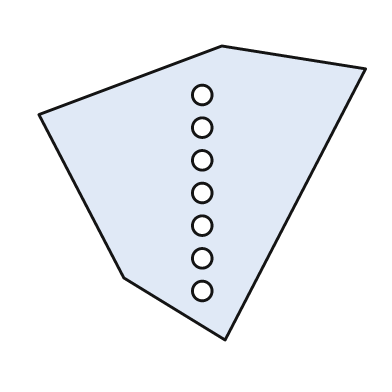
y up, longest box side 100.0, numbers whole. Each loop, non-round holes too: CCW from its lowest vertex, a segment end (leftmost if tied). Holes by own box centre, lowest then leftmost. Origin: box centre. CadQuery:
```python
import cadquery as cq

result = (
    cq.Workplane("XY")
    .moveTo(7.0, -45.0)
    .lineTo(50.0, 38.0)
    .lineTo(6.0, 45.0)
    .lineTo(-50.0, 24.0)
    .lineTo(-24.0, -26.0)
    .close()
    .moveTo(0.0, -30.0)
    .circle(3.0)
    .moveTo(0.0, -20.0)
    .circle(3.0)
    .moveTo(0.0, -10.0)
    .circle(3.0)
    .moveTo(0.0, 0.0)
    .circle(3.0)
    .moveTo(0.0, 10.0)
    .circle(3.0)
    .moveTo(0.0, 20.0)
    .circle(3.0)
    .moveTo(0.0, 30.0)
    .circle(3.0)
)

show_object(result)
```